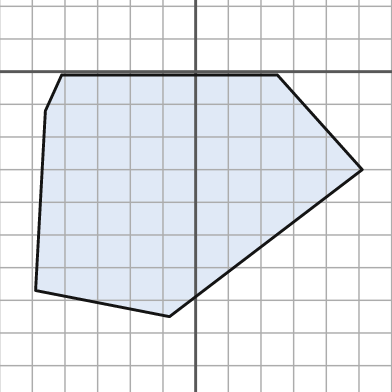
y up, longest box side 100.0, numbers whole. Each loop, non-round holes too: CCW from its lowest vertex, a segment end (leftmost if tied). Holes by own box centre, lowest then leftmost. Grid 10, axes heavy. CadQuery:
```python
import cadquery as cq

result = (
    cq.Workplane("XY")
    .moveTo(-8.0, -75.0)
    .lineTo(51.0, -30.0)
    .lineTo(25.0, -1.0)
    .lineTo(-41.0, -1.0)
    .lineTo(-46.0, -12.0)
    .lineTo(-49.0, -67.0)
    .close()
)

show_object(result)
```